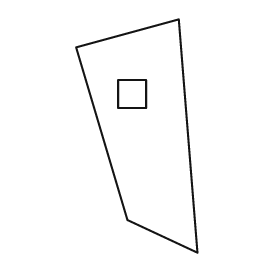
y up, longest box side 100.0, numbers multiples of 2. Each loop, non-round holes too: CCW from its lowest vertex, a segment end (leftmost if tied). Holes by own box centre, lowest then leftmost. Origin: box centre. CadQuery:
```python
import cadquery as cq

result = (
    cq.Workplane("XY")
    .moveTo(26.0, -50.0)
    .lineTo(18.0, 50.0)
    .lineTo(-26.0, 38.0)
    .lineTo(-4.0, -36.0)
    .close()
    .moveTo(-8.0, 12.0)
    .lineTo(4.0, 12.0)
    .lineTo(4.0, 24.0)
    .lineTo(-8.0, 24.0)
    .close()
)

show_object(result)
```